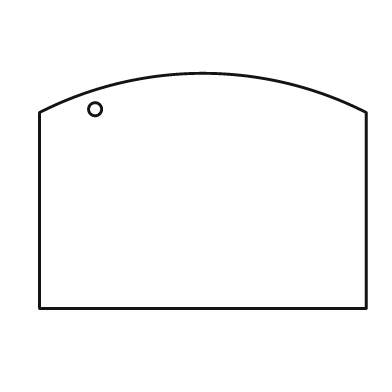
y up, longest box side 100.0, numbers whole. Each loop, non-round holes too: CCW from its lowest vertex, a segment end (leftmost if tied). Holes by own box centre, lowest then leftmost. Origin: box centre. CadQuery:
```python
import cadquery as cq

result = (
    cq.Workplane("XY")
    .moveTo(-50.0, -36.0)
    .lineTo(50.0, -36.0)
    .lineTo(50.0, 24.0)
    .threePointArc((0.0, 36.0), (-50.0, 24.0))
    .close()
    .moveTo(-33.0, 25.0)
    .circle(2.0)
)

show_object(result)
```